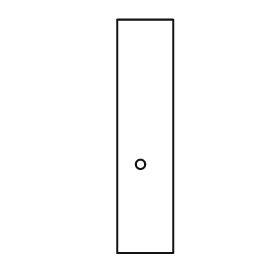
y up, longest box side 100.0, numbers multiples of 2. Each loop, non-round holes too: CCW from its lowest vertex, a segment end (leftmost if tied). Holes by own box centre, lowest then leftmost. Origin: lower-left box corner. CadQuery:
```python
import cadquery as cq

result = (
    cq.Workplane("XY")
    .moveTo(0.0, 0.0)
    .lineTo(24.0, 0.0)
    .lineTo(24.0, 100.0)
    .lineTo(0.0, 100.0)
    .close()
    .moveTo(10.0, 38.0)
    .circle(2.0)
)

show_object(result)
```